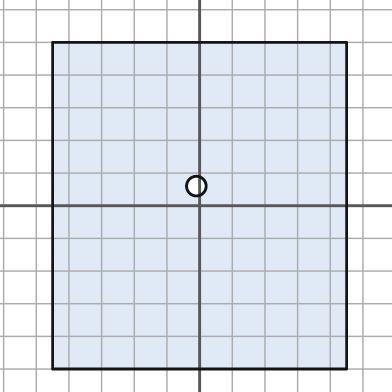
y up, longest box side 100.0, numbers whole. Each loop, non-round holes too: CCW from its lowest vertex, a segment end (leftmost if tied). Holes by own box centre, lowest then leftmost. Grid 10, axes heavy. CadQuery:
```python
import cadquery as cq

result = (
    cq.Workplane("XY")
    .moveTo(-45.0, -50.0)
    .lineTo(45.0, -50.0)
    .lineTo(45.0, 50.0)
    .lineTo(-45.0, 50.0)
    .close()
    .moveTo(-1.0, 6.0)
    .circle(3.0)
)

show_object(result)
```